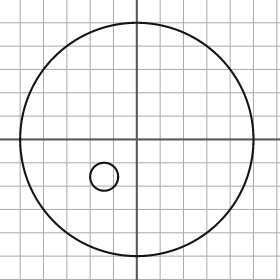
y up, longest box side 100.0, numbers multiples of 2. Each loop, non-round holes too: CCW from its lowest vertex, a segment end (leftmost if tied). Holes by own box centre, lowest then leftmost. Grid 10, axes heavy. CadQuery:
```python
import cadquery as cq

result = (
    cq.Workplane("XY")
    .moveTo(0.0, 0.0)
    .circle(50.0)
    .moveTo(-14.0, -16.0)
    .circle(6.0)
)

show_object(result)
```